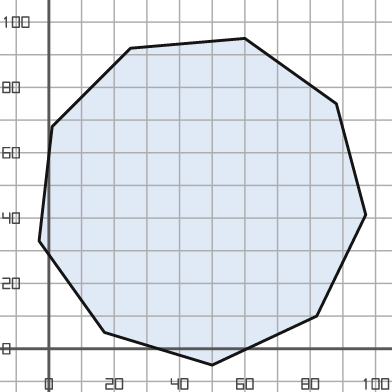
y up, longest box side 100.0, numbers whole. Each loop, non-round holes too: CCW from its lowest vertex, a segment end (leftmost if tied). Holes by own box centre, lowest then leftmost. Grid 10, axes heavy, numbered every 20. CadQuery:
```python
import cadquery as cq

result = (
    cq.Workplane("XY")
    .moveTo(50.0, -5.0)
    .lineTo(82.0, 10.0)
    .lineTo(97.0, 41.0)
    .lineTo(88.0, 75.0)
    .lineTo(60.0, 95.0)
    .lineTo(25.0, 92.0)
    .lineTo(1.0, 68.0)
    .lineTo(-3.0, 33.0)
    .lineTo(17.0, 5.0)
    .close()
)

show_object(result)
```